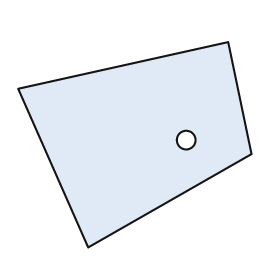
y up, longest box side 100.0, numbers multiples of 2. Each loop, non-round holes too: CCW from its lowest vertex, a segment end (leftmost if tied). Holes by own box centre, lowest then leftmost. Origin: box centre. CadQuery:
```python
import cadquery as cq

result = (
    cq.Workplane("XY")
    .moveTo(-20.0, -44.0)
    .lineTo(50.0, -4.0)
    .lineTo(40.0, 44.0)
    .lineTo(-50.0, 24.0)
    .close()
    .moveTo(22.0, 2.0)
    .circle(4.0)
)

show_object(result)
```